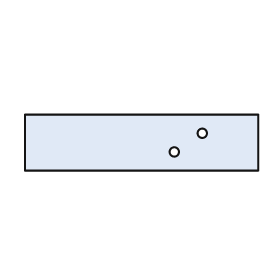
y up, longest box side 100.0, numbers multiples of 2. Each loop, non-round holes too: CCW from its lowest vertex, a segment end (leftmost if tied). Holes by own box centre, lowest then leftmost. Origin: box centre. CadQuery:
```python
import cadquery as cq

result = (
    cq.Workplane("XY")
    .moveTo(-50.0, -12.0)
    .lineTo(50.0, -12.0)
    .lineTo(50.0, 12.0)
    .lineTo(-50.0, 12.0)
    .close()
    .moveTo(14.0, -4.0)
    .circle(2.0)
    .moveTo(26.0, 4.0)
    .circle(2.0)
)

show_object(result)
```